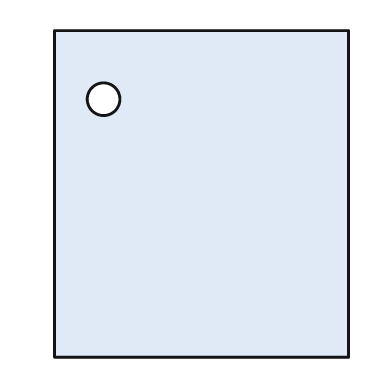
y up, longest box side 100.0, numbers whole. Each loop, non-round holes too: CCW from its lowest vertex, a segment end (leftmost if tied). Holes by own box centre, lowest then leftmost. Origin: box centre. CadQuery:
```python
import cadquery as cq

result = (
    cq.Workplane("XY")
    .moveTo(-45.0, -50.0)
    .lineTo(45.0, -50.0)
    .lineTo(45.0, 50.0)
    .lineTo(-45.0, 50.0)
    .close()
    .moveTo(-30.0, 29.0)
    .circle(5.0)
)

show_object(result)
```